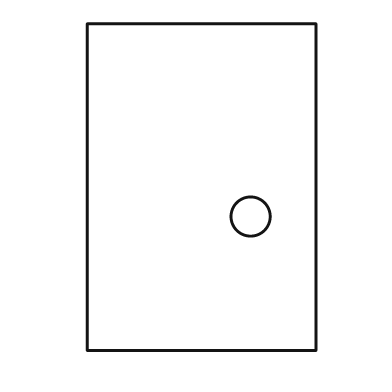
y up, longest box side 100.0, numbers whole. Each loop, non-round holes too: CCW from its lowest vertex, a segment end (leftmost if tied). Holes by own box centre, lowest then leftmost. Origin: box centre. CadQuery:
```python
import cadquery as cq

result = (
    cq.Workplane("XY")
    .moveTo(-35.0, -50.0)
    .lineTo(35.0, -50.0)
    .lineTo(35.0, 50.0)
    .lineTo(-35.0, 50.0)
    .close()
    .moveTo(15.0, -9.0)
    .circle(6.0)
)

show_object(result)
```